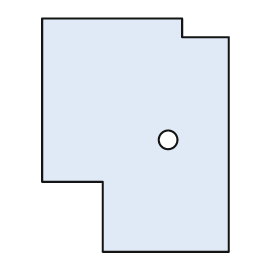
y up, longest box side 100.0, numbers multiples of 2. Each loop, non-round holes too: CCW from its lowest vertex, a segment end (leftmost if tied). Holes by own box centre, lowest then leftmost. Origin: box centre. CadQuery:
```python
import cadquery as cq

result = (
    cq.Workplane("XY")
    .moveTo(-14.0, -50.0)
    .lineTo(40.0, -50.0)
    .lineTo(40.0, 42.0)
    .lineTo(20.0, 42.0)
    .lineTo(20.0, 50.0)
    .lineTo(-40.0, 50.0)
    .lineTo(-40.0, -20.0)
    .lineTo(-14.0, -20.0)
    .close()
    .moveTo(14.0, -2.0)
    .circle(4.0)
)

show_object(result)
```